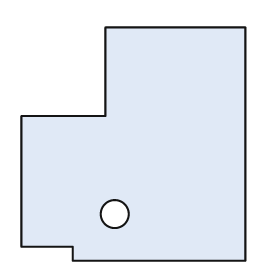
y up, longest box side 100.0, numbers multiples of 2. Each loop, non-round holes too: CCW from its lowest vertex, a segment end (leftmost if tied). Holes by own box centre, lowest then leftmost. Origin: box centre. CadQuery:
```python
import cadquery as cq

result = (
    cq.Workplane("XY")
    .moveTo(-26.0, -50.0)
    .lineTo(48.0, -50.0)
    .lineTo(48.0, 50.0)
    .lineTo(-12.0, 50.0)
    .lineTo(-12.0, 12.0)
    .lineTo(-48.0, 12.0)
    .lineTo(-48.0, -44.0)
    .lineTo(-26.0, -44.0)
    .close()
    .moveTo(-8.0, -30.0)
    .circle(6.0)
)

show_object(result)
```